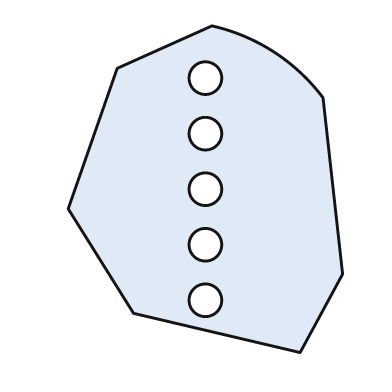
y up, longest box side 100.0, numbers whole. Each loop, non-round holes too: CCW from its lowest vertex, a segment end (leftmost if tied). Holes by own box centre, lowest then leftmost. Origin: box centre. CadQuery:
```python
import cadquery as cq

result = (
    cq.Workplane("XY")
    .moveTo(29.0, -50.0)
    .lineTo(42.0, -26.0)
    .lineTo(36.0, 28.0)
    .threePointArc((21.0, 42.0), (2.0, 50.0))
    .lineTo(-27.0, 37.0)
    .lineTo(-42.0, -6.0)
    .lineTo(-22.0, -38.0)
    .close()
    .moveTo(0.0, -34.0)
    .circle(5.0)
    .moveTo(0.0, -17.0)
    .circle(5.0)
    .moveTo(0.0, 0.0)
    .circle(5.0)
    .moveTo(0.0, 17.0)
    .circle(5.0)
    .moveTo(0.0, 34.0)
    .circle(5.0)
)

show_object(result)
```